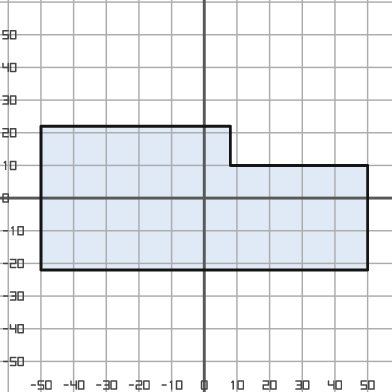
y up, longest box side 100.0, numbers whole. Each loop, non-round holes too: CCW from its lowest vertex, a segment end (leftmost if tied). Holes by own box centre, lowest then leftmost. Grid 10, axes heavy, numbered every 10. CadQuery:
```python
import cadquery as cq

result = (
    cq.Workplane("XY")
    .moveTo(-50.0, -22.0)
    .lineTo(50.0, -22.0)
    .lineTo(50.0, 10.0)
    .lineTo(8.0, 10.0)
    .lineTo(8.0, 22.0)
    .lineTo(-50.0, 22.0)
    .close()
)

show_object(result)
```